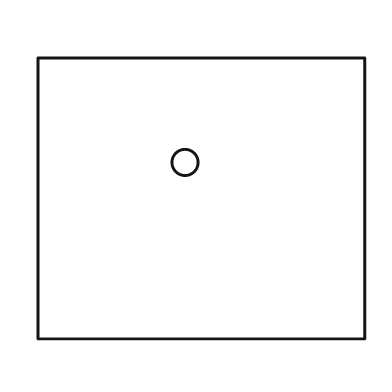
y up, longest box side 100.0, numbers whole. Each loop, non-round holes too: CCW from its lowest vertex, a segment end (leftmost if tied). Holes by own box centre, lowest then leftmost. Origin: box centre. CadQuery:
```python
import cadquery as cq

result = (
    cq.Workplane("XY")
    .moveTo(-50.0, -43.0)
    .lineTo(50.0, -43.0)
    .lineTo(50.0, 43.0)
    .lineTo(-50.0, 43.0)
    .close()
    .moveTo(-5.0, 11.0)
    .circle(4.0)
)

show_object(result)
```